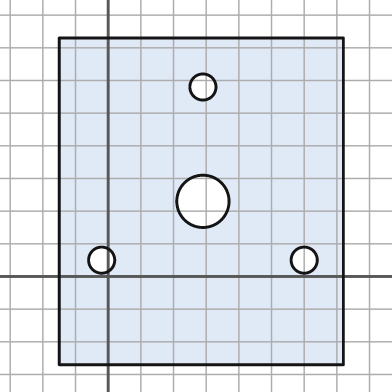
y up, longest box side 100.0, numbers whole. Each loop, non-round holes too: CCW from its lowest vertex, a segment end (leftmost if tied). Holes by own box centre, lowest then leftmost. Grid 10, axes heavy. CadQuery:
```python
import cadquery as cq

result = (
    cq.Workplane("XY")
    .moveTo(-15.0, -27.0)
    .lineTo(72.0, -27.0)
    .lineTo(72.0, 73.0)
    .lineTo(-15.0, 73.0)
    .close()
    .moveTo(-2.0, 5.0)
    .circle(4.0)
    .moveTo(60.0, 5.0)
    .circle(4.0)
    .moveTo(29.0, 23.0)
    .circle(8.0)
    .moveTo(29.0, 58.0)
    .circle(4.0)
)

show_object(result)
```